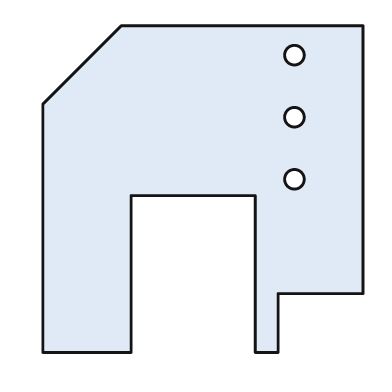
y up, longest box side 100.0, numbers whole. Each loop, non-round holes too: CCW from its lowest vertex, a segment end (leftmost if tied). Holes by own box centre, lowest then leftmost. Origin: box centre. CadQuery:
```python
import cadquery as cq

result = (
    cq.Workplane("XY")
    .moveTo(-49.0, -50.0)
    .lineTo(-22.0, -50.0)
    .lineTo(-22.0, -2.0)
    .lineTo(16.0, -2.0)
    .lineTo(16.0, -50.0)
    .lineTo(23.0, -50.0)
    .lineTo(23.0, -32.0)
    .lineTo(49.0, -32.0)
    .lineTo(49.0, 50.0)
    .lineTo(-25.0, 50.0)
    .lineTo(-49.0, 26.0)
    .close()
    .moveTo(28.0, 3.0)
    .circle(3.0)
    .moveTo(28.0, 22.0)
    .circle(3.0)
    .moveTo(28.0, 41.0)
    .circle(3.0)
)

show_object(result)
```